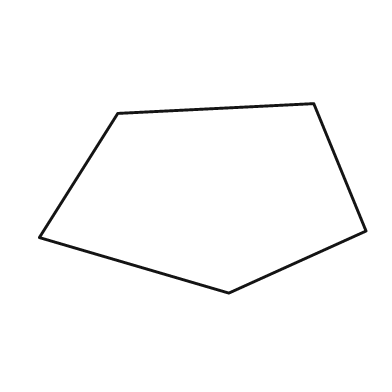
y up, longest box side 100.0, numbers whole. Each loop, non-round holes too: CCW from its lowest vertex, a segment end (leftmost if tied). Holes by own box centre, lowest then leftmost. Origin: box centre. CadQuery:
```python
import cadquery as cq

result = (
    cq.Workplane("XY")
    .moveTo(8.0, -29.0)
    .lineTo(50.0, -10.0)
    .lineTo(34.0, 29.0)
    .lineTo(-26.0, 26.0)
    .lineTo(-50.0, -12.0)
    .close()
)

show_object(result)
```